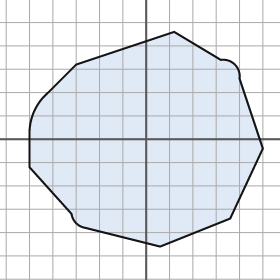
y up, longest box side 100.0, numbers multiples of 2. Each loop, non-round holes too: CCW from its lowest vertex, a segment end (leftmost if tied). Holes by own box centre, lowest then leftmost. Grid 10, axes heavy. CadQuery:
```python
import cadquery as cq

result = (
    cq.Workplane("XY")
    .moveTo(6.0, -46.0)
    .lineTo(36.0, -34.0)
    .lineTo(50.0, -4.0)
    .lineTo(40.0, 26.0)
    .threePointArc((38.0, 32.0), (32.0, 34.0))
    .lineTo(12.0, 46.0)
    .lineTo(-30.0, 32.0)
    .lineTo(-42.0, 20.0)
    .threePointArc((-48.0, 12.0), (-50.0, 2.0))
    .lineTo(-50.0, -12.0)
    .lineTo(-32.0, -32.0)
    .threePointArc((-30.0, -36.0), (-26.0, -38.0))
    .close()
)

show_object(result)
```